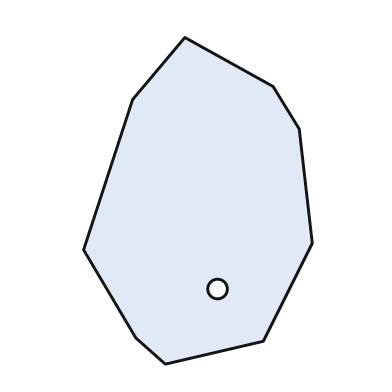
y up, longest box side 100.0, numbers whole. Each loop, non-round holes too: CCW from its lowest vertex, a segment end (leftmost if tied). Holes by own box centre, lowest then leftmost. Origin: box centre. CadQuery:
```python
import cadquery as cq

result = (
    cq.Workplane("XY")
    .moveTo(-10.0, -50.0)
    .lineTo(20.0, -43.0)
    .lineTo(35.0, -13.0)
    .lineTo(31.0, 22.0)
    .lineTo(23.0, 35.0)
    .lineTo(-4.0, 50.0)
    .lineTo(-20.0, 31.0)
    .lineTo(-35.0, -15.0)
    .lineTo(-19.0, -42.0)
    .close()
    .moveTo(6.0, -27.0)
    .circle(3.0)
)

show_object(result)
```